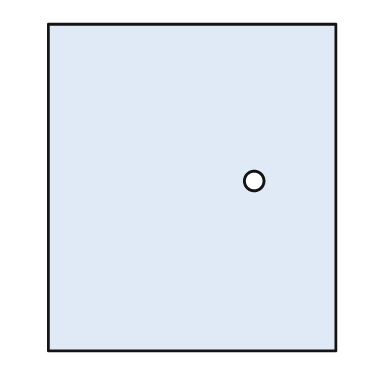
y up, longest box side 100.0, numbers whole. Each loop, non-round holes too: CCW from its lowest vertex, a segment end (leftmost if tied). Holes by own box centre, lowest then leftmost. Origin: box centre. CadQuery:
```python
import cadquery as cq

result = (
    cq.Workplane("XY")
    .moveTo(-44.0, -50.0)
    .lineTo(44.0, -50.0)
    .lineTo(44.0, 50.0)
    .lineTo(-44.0, 50.0)
    .close()
    .moveTo(19.0, 2.0)
    .circle(3.0)
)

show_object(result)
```